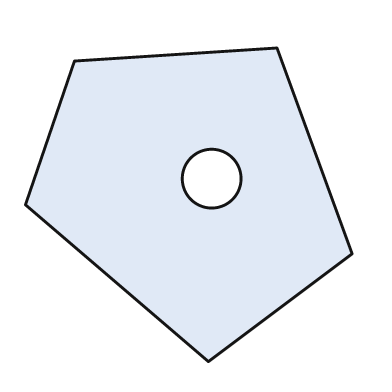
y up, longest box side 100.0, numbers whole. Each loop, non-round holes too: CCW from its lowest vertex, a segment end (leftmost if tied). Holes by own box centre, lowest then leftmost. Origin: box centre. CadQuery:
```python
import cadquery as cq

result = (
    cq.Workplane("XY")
    .moveTo(6.0, -48.0)
    .lineTo(50.0, -15.0)
    .lineTo(27.0, 48.0)
    .lineTo(-35.0, 44.0)
    .lineTo(-50.0, 0.0)
    .close()
    .moveTo(7.0, 8.0)
    .circle(9.0)
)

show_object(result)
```